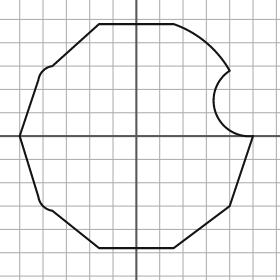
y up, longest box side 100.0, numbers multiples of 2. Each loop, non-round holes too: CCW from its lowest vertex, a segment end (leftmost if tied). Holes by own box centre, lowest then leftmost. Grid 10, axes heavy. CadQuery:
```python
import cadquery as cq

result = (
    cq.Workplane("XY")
    .moveTo(-16.0, -48.0)
    .lineTo(16.0, -48.0)
    .lineTo(40.0, -30.0)
    .lineTo(50.0, 0.0)
    .threePointArc((34.0, 10.0), (40.0, 28.0))
    .threePointArc((30.0, 40.0), (16.0, 48.0))
    .lineTo(-16.0, 48.0)
    .lineTo(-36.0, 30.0)
    .threePointArc((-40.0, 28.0), (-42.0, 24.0))
    .lineTo(-50.0, 0.0)
    .lineTo(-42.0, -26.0)
    .threePointArc((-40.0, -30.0), (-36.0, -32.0))
    .close()
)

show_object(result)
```